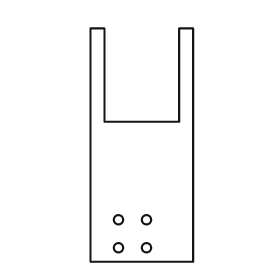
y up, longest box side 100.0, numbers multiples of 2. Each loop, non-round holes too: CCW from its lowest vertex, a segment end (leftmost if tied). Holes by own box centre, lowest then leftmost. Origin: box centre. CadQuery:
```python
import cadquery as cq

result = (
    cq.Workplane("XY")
    .moveTo(-22.0, -50.0)
    .lineTo(22.0, -50.0)
    .lineTo(22.0, 50.0)
    .lineTo(16.0, 50.0)
    .lineTo(16.0, 10.0)
    .lineTo(-16.0, 10.0)
    .lineTo(-16.0, 50.0)
    .lineTo(-22.0, 50.0)
    .close()
    .moveTo(-10.0, -44.0)
    .circle(2.0)
    .moveTo(2.0, -44.0)
    .circle(2.0)
    .moveTo(-10.0, -32.0)
    .circle(2.0)
    .moveTo(2.0, -32.0)
    .circle(2.0)
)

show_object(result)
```